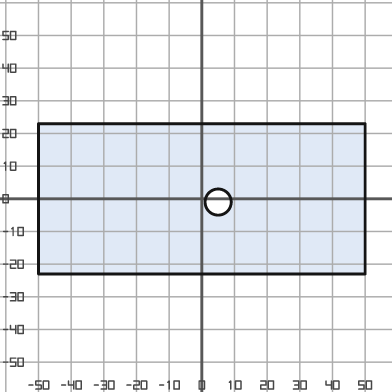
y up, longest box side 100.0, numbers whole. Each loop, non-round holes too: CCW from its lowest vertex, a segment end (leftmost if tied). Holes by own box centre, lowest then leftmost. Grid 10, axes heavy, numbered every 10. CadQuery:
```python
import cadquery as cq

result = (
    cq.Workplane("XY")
    .moveTo(-50.0, -23.0)
    .lineTo(50.0, -23.0)
    .lineTo(50.0, 23.0)
    .lineTo(-50.0, 23.0)
    .close()
    .moveTo(5.0, -1.0)
    .circle(4.0)
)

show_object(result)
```